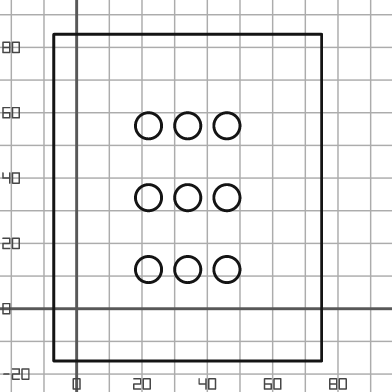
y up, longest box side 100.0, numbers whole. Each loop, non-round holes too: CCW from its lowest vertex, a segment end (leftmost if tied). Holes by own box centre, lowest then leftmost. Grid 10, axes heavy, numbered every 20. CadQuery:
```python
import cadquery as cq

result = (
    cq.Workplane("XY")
    .moveTo(-7.0, -16.0)
    .lineTo(75.0, -16.0)
    .lineTo(75.0, 84.0)
    .lineTo(-7.0, 84.0)
    .close()
    .moveTo(22.0, 12.0)
    .circle(4.0)
    .moveTo(34.0, 12.0)
    .circle(4.0)
    .moveTo(46.0, 12.0)
    .circle(4.0)
    .moveTo(22.0, 34.0)
    .circle(4.0)
    .moveTo(34.0, 34.0)
    .circle(4.0)
    .moveTo(46.0, 34.0)
    .circle(4.0)
    .moveTo(22.0, 56.0)
    .circle(4.0)
    .moveTo(34.0, 56.0)
    .circle(4.0)
    .moveTo(46.0, 56.0)
    .circle(4.0)
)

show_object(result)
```